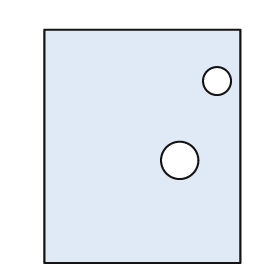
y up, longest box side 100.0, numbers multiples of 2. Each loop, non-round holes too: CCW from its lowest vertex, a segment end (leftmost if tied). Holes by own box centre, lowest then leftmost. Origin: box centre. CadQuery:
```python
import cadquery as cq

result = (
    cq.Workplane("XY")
    .moveTo(-42.0, -50.0)
    .lineTo(42.0, -50.0)
    .lineTo(42.0, 50.0)
    .lineTo(-42.0, 50.0)
    .close()
    .moveTo(16.0, -6.0)
    .circle(8.0)
    .moveTo(32.0, 28.0)
    .circle(6.0)
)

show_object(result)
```